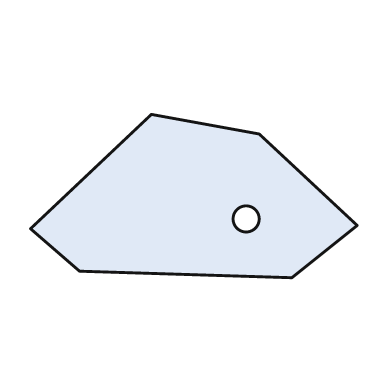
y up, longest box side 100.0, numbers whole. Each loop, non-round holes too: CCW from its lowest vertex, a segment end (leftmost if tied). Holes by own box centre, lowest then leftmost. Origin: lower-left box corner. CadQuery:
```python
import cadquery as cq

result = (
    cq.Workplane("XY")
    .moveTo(80.0, 0.0)
    .lineTo(100.0, 16.0)
    .lineTo(70.0, 44.0)
    .lineTo(37.0, 50.0)
    .lineTo(0.0, 15.0)
    .lineTo(15.0, 2.0)
    .close()
    .moveTo(66.0, 18.0)
    .circle(4.0)
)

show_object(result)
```